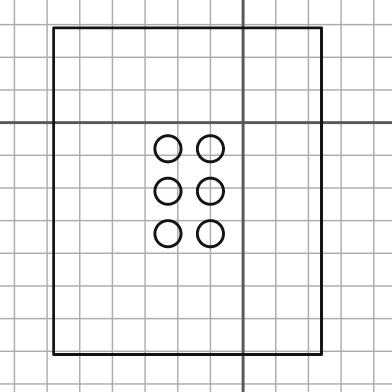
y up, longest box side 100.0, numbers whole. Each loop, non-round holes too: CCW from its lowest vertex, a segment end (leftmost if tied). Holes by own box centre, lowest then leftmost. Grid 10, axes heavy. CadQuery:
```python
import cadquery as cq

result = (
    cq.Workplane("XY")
    .moveTo(-58.0, -71.0)
    .lineTo(24.0, -71.0)
    .lineTo(24.0, 29.0)
    .lineTo(-58.0, 29.0)
    .close()
    .moveTo(-23.0, -34.0)
    .circle(4.0)
    .moveTo(-10.0, -34.0)
    .circle(4.0)
    .moveTo(-23.0, -21.0)
    .circle(4.0)
    .moveTo(-10.0, -21.0)
    .circle(4.0)
    .moveTo(-23.0, -8.0)
    .circle(4.0)
    .moveTo(-10.0, -8.0)
    .circle(4.0)
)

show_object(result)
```